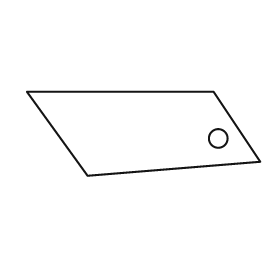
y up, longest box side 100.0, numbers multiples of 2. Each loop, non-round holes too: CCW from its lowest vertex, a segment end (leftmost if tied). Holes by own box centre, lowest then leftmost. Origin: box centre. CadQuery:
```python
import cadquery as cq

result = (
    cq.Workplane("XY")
    .moveTo(-24.0, -18.0)
    .lineTo(50.0, -12.0)
    .lineTo(30.0, 18.0)
    .lineTo(-50.0, 18.0)
    .close()
    .moveTo(32.0, -2.0)
    .circle(4.0)
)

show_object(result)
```